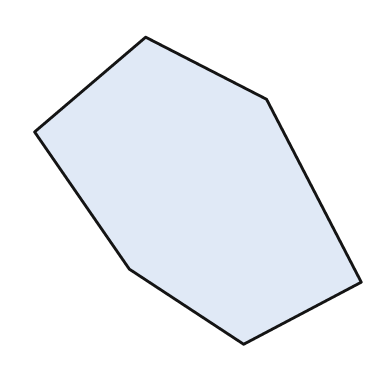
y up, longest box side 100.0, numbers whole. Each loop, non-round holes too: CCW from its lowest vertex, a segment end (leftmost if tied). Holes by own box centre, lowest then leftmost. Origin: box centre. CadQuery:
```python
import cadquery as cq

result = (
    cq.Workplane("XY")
    .moveTo(14.0, -47.0)
    .lineTo(50.0, -28.0)
    .lineTo(21.0, 28.0)
    .lineTo(-16.0, 47.0)
    .lineTo(-50.0, 18.0)
    .lineTo(-21.0, -24.0)
    .close()
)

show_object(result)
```